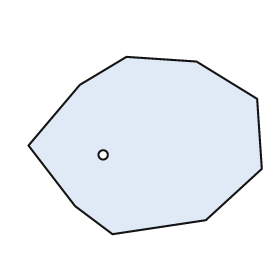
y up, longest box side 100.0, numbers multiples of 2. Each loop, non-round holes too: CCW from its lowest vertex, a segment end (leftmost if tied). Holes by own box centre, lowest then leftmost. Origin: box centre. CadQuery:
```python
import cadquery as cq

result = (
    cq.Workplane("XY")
    .moveTo(-14.0, -38.0)
    .lineTo(26.0, -32.0)
    .lineTo(50.0, -10.0)
    .lineTo(48.0, 20.0)
    .lineTo(22.0, 36.0)
    .lineTo(-8.0, 38.0)
    .lineTo(-28.0, 26.0)
    .lineTo(-50.0, 0.0)
    .lineTo(-30.0, -26.0)
    .close()
    .moveTo(-18.0, -4.0)
    .circle(2.0)
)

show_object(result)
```